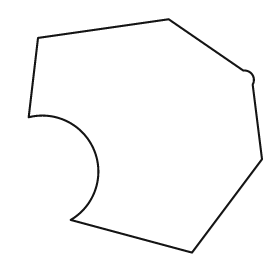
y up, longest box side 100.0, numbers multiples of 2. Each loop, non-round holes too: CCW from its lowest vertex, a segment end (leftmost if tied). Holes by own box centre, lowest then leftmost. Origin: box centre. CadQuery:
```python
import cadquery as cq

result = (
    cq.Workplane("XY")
    .moveTo(20.0, -50.0)
    .lineTo(50.0, -10.0)
    .lineTo(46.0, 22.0)
    .threePointArc((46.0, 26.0), (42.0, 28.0))
    .lineTo(10.0, 50.0)
    .lineTo(-46.0, 42.0)
    .lineTo(-50.0, 8.0)
    .threePointArc((-22.0, -6.0), (-32.0, -36.0))
    .close()
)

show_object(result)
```